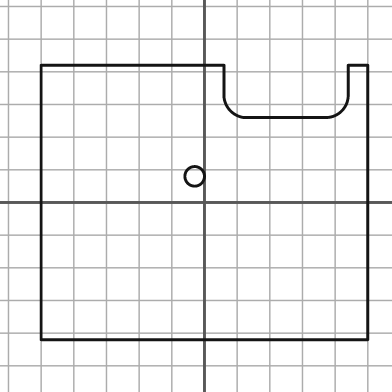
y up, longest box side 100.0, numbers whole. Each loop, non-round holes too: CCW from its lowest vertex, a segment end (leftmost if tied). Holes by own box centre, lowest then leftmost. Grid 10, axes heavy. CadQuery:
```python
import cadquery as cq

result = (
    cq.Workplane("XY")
    .moveTo(-50.0, -42.0)
    .lineTo(50.0, -42.0)
    .lineTo(50.0, 42.0)
    .lineTo(44.0, 42.0)
    .lineTo(44.0, 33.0)
    .threePointArc((42.0, 28.0), (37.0, 26.0))
    .lineTo(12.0, 26.0)
    .threePointArc((8.0, 28.0), (6.0, 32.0))
    .lineTo(6.0, 42.0)
    .lineTo(-50.0, 42.0)
    .close()
    .moveTo(-3.0, 8.0)
    .circle(3.0)
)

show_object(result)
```